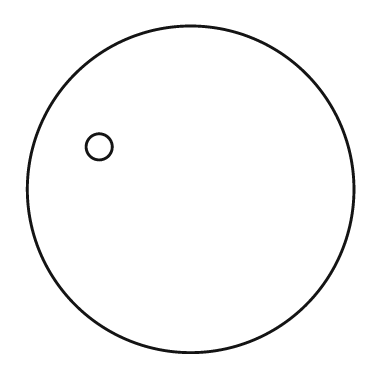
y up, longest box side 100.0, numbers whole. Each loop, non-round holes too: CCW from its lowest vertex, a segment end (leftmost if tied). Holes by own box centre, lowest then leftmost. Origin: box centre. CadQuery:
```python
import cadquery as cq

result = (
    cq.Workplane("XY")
    .moveTo(0.0, 0.0)
    .circle(50.0)
    .moveTo(-28.0, 13.0)
    .circle(4.0)
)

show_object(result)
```